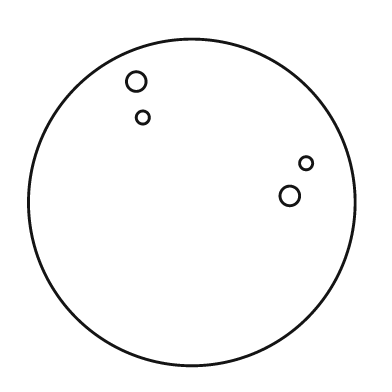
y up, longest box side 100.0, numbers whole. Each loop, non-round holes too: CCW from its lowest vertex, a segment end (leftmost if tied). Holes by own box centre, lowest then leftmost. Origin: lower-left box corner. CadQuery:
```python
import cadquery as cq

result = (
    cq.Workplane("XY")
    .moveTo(50.0, 50.0)
    .circle(50.0)
    .moveTo(80.0, 52.0)
    .circle(3.0)
    .moveTo(85.0, 62.0)
    .circle(2.0)
    .moveTo(35.0, 76.0)
    .circle(2.0)
    .moveTo(33.0, 87.0)
    .circle(3.0)
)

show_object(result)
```